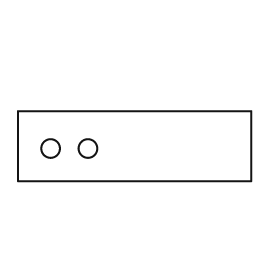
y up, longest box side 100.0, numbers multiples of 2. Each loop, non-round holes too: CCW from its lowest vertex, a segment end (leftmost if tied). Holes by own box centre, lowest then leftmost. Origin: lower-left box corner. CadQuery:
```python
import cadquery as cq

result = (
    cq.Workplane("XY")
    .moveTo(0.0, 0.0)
    .lineTo(100.0, 0.0)
    .lineTo(100.0, 30.0)
    .lineTo(0.0, 30.0)
    .close()
    .moveTo(14.0, 14.0)
    .circle(4.0)
    .moveTo(30.0, 14.0)
    .circle(4.0)
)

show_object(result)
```